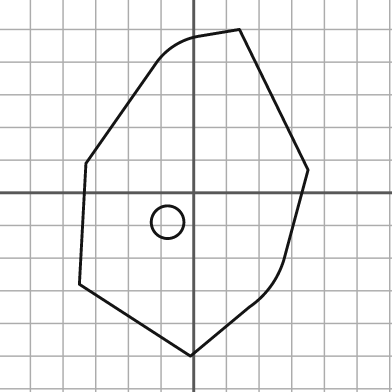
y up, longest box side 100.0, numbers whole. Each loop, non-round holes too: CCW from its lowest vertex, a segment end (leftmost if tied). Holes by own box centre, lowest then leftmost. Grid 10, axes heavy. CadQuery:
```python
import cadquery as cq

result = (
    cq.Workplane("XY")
    .moveTo(-1.0, -50.0)
    .lineTo(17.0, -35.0)
    .threePointArc((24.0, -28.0), (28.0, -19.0))
    .lineTo(35.0, 7.0)
    .lineTo(14.0, 50.0)
    .lineTo(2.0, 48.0)
    .threePointArc((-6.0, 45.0), (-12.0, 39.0))
    .lineTo(-33.0, 9.0)
    .lineTo(-35.0, -28.0)
    .close()
    .moveTo(-8.0, -9.0)
    .circle(5.0)
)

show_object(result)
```